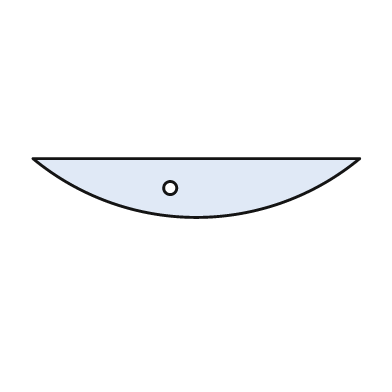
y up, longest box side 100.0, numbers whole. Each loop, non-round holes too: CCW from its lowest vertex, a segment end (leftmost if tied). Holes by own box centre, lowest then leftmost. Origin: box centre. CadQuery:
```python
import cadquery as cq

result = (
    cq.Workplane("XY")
    .moveTo(-50.0, 9.0)
    .threePointArc((0.0, -9.0), (50.0, 9.0))
    .close()
    .moveTo(-8.0, 0.0)
    .circle(2.0)
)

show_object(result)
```